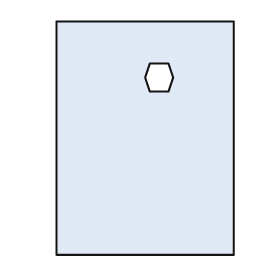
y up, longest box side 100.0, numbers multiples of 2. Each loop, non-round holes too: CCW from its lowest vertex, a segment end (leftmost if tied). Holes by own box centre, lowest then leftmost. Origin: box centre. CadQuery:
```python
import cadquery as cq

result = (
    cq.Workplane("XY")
    .moveTo(-38.0, -50.0)
    .lineTo(38.0, -50.0)
    .lineTo(38.0, 50.0)
    .lineTo(-38.0, 50.0)
    .close()
    .moveTo(2.0, 20.0)
    .lineTo(10.0, 20.0)
    .lineTo(12.0, 26.0)
    .lineTo(10.0, 32.0)
    .lineTo(2.0, 32.0)
    .lineTo(0.0, 26.0)
    .close()
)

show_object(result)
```